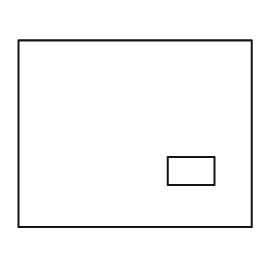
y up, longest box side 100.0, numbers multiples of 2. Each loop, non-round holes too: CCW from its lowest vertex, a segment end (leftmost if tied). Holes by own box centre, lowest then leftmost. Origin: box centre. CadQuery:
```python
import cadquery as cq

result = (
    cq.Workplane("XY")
    .moveTo(-50.0, -40.0)
    .lineTo(50.0, -40.0)
    .lineTo(50.0, 40.0)
    .lineTo(-50.0, 40.0)
    .close()
    .moveTo(14.0, -22.0)
    .lineTo(34.0, -22.0)
    .lineTo(34.0, -10.0)
    .lineTo(14.0, -10.0)
    .close()
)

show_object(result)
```